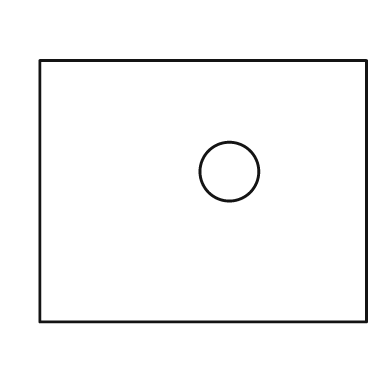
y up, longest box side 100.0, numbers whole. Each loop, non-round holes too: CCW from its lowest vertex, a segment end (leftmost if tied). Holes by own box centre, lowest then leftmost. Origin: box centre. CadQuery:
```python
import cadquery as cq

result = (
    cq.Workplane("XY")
    .moveTo(-50.0, -40.0)
    .lineTo(50.0, -40.0)
    .lineTo(50.0, 40.0)
    .lineTo(-50.0, 40.0)
    .close()
    .moveTo(8.0, 6.0)
    .circle(9.0)
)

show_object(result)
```